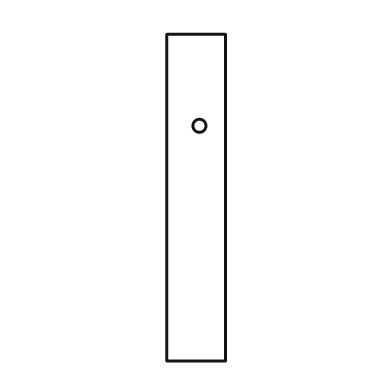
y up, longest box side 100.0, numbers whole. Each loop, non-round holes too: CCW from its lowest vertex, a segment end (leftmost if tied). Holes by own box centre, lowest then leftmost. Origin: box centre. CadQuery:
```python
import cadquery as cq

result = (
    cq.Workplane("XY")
    .moveTo(-9.0, -50.0)
    .lineTo(9.0, -50.0)
    .lineTo(9.0, 50.0)
    .lineTo(-9.0, 50.0)
    .close()
    .moveTo(1.0, 22.0)
    .circle(2.0)
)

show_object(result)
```